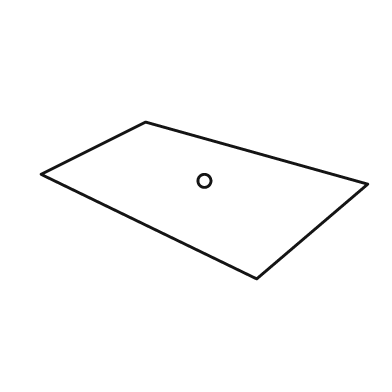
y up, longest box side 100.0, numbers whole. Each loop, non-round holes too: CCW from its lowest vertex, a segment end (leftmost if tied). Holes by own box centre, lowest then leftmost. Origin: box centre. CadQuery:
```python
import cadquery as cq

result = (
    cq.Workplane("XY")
    .moveTo(16.0, -24.0)
    .lineTo(50.0, 5.0)
    .lineTo(-18.0, 24.0)
    .lineTo(-50.0, 8.0)
    .close()
    .moveTo(0.0, 6.0)
    .circle(2.0)
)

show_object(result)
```